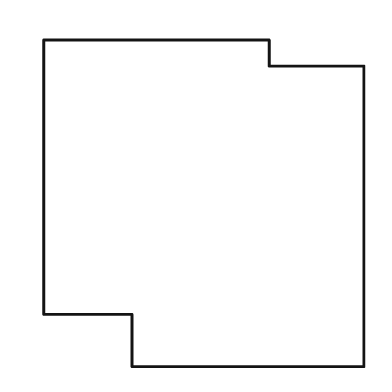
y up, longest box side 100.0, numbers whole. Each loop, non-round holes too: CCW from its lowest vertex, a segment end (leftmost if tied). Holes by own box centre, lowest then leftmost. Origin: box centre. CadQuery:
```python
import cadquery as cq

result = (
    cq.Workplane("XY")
    .moveTo(-22.0, -50.0)
    .lineTo(49.0, -50.0)
    .lineTo(49.0, 42.0)
    .lineTo(20.0, 42.0)
    .lineTo(20.0, 50.0)
    .lineTo(-49.0, 50.0)
    .lineTo(-49.0, -34.0)
    .lineTo(-22.0, -34.0)
    .close()
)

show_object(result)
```